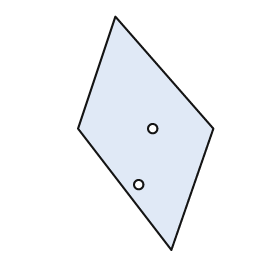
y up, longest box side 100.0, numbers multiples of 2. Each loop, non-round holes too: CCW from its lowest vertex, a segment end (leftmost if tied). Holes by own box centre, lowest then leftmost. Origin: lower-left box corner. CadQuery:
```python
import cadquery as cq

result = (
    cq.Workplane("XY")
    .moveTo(40.0, 0.0)
    .lineTo(58.0, 52.0)
    .lineTo(16.0, 100.0)
    .lineTo(0.0, 52.0)
    .close()
    .moveTo(26.0, 28.0)
    .circle(2.0)
    .moveTo(32.0, 52.0)
    .circle(2.0)
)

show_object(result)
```